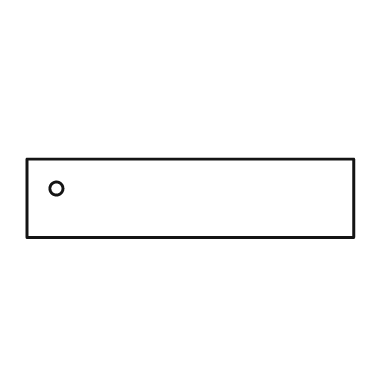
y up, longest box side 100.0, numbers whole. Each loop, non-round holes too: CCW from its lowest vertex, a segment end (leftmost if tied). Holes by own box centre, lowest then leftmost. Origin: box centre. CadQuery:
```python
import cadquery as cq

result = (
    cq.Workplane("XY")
    .moveTo(-50.0, -12.0)
    .lineTo(50.0, -12.0)
    .lineTo(50.0, 12.0)
    .lineTo(-50.0, 12.0)
    .close()
    .moveTo(-41.0, 3.0)
    .circle(2.0)
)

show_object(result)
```